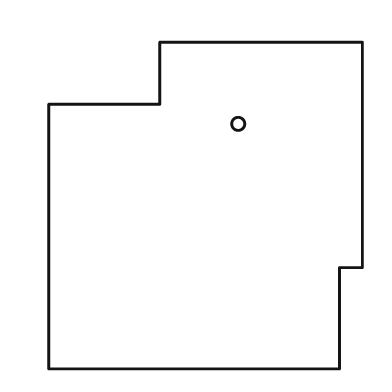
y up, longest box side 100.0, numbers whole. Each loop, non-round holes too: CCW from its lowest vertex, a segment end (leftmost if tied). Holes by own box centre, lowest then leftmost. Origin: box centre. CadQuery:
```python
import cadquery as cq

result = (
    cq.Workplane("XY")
    .moveTo(-48.0, -50.0)
    .lineTo(41.0, -50.0)
    .lineTo(41.0, -19.0)
    .lineTo(48.0, -19.0)
    .lineTo(48.0, 50.0)
    .lineTo(-14.0, 50.0)
    .lineTo(-14.0, 31.0)
    .lineTo(-48.0, 31.0)
    .close()
    .moveTo(10.0, 25.0)
    .circle(2.0)
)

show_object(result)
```